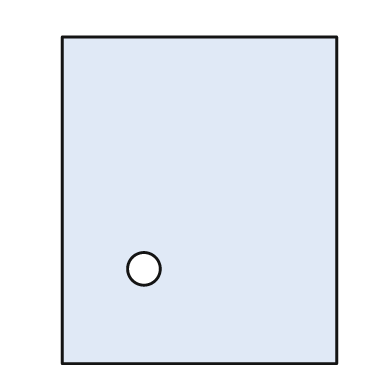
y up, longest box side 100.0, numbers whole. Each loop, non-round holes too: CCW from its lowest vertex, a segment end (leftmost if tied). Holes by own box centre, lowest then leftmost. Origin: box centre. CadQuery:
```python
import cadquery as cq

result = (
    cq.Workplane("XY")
    .moveTo(-42.0, -50.0)
    .lineTo(42.0, -50.0)
    .lineTo(42.0, 50.0)
    .lineTo(-42.0, 50.0)
    .close()
    .moveTo(-17.0, -21.0)
    .circle(5.0)
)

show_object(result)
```